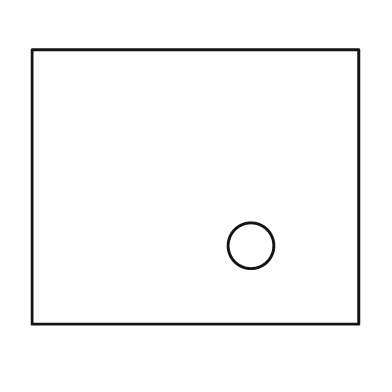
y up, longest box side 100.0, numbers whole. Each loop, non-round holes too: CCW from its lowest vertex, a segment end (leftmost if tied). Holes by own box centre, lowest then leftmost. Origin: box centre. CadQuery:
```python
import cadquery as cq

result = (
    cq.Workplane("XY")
    .moveTo(-50.0, -42.0)
    .lineTo(50.0, -42.0)
    .lineTo(50.0, 42.0)
    .lineTo(-50.0, 42.0)
    .close()
    .moveTo(17.0, -18.0)
    .circle(7.0)
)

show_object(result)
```